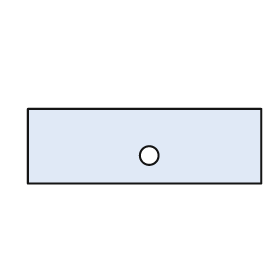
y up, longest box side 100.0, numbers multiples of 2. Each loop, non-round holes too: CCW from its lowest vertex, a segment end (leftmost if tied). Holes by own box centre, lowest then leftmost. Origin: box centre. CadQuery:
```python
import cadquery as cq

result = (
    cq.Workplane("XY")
    .moveTo(-50.0, -16.0)
    .lineTo(50.0, -16.0)
    .lineTo(50.0, 16.0)
    .lineTo(-50.0, 16.0)
    .close()
    .moveTo(2.0, -4.0)
    .circle(4.0)
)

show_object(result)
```